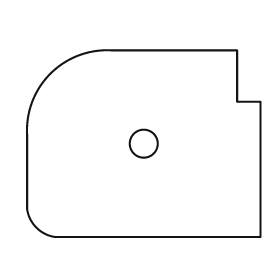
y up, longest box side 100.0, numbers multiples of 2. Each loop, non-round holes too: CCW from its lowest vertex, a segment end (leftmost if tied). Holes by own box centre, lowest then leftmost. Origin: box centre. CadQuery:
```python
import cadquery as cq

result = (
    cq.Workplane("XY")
    .moveTo(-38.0, -40.0)
    .lineTo(50.0, -40.0)
    .lineTo(50.0, 18.0)
    .lineTo(40.0, 18.0)
    .lineTo(40.0, 40.0)
    .lineTo(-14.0, 40.0)
    .threePointArc((-40.0, 30.0), (-50.0, 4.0))
    .lineTo(-50.0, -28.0)
    .threePointArc((-46.0, -36.0), (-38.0, -40.0))
    .close()
    .moveTo(0.0, 0.0)
    .circle(6.0)
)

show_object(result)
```